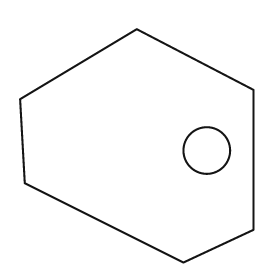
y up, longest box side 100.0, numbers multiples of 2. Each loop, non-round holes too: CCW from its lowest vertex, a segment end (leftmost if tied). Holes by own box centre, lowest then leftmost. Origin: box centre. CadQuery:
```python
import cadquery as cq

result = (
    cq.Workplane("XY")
    .moveTo(20.0, -50.0)
    .lineTo(50.0, -36.0)
    .lineTo(50.0, 24.0)
    .lineTo(0.0, 50.0)
    .lineTo(-50.0, 20.0)
    .lineTo(-48.0, -16.0)
    .close()
    .moveTo(30.0, -2.0)
    .circle(10.0)
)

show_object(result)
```